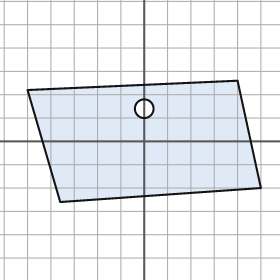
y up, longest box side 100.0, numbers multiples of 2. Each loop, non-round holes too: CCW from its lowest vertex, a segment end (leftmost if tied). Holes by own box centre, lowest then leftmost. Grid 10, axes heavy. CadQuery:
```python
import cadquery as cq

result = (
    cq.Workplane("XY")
    .moveTo(-36.0, -26.0)
    .lineTo(50.0, -20.0)
    .lineTo(40.0, 26.0)
    .lineTo(-50.0, 22.0)
    .close()
    .moveTo(0.0, 14.0)
    .circle(4.0)
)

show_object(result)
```